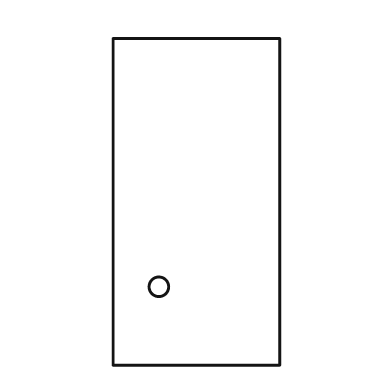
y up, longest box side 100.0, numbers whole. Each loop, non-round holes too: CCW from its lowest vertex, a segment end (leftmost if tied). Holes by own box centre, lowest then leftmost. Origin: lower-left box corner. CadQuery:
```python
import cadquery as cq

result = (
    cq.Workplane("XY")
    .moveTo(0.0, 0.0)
    .lineTo(51.0, 0.0)
    .lineTo(51.0, 100.0)
    .lineTo(0.0, 100.0)
    .close()
    .moveTo(14.0, 24.0)
    .circle(3.0)
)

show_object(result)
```